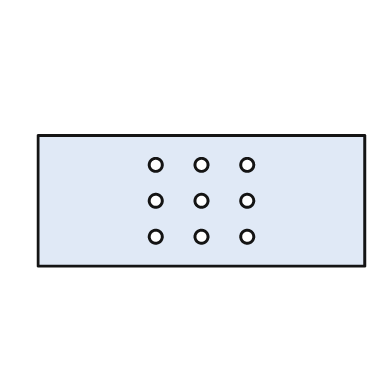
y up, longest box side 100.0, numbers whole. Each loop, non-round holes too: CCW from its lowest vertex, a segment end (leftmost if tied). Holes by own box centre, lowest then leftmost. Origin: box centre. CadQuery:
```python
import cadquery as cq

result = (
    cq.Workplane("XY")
    .moveTo(-50.0, -20.0)
    .lineTo(50.0, -20.0)
    .lineTo(50.0, 20.0)
    .lineTo(-50.0, 20.0)
    .close()
    .moveTo(-14.0, -11.0)
    .circle(2.0)
    .moveTo(0.0, -11.0)
    .circle(2.0)
    .moveTo(14.0, -11.0)
    .circle(2.0)
    .moveTo(-14.0, 0.0)
    .circle(2.0)
    .moveTo(0.0, 0.0)
    .circle(2.0)
    .moveTo(14.0, 0.0)
    .circle(2.0)
    .moveTo(-14.0, 11.0)
    .circle(2.0)
    .moveTo(0.0, 11.0)
    .circle(2.0)
    .moveTo(14.0, 11.0)
    .circle(2.0)
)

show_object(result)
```